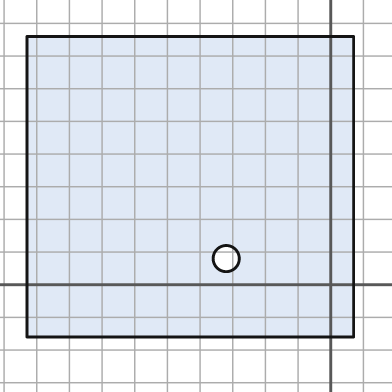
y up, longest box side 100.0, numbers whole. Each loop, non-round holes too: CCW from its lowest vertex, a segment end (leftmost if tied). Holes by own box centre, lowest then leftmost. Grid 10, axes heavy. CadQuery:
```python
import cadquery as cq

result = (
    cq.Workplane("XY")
    .moveTo(-93.0, -16.0)
    .lineTo(7.0, -16.0)
    .lineTo(7.0, 76.0)
    .lineTo(-93.0, 76.0)
    .close()
    .moveTo(-32.0, 8.0)
    .circle(4.0)
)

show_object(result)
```